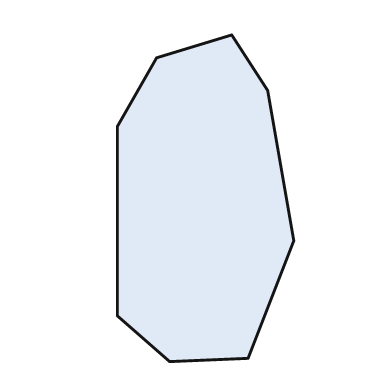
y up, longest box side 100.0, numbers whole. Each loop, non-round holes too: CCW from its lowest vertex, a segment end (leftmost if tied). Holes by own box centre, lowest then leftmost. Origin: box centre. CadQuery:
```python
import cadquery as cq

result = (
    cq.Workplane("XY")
    .moveTo(-11.0, -50.0)
    .lineTo(13.0, -49.0)
    .lineTo(27.0, -13.0)
    .lineTo(19.0, 33.0)
    .lineTo(8.0, 50.0)
    .lineTo(-15.0, 43.0)
    .lineTo(-27.0, 22.0)
    .lineTo(-27.0, -36.0)
    .close()
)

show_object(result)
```